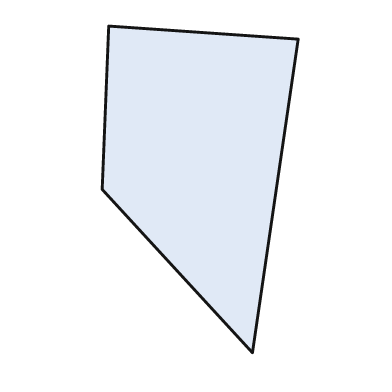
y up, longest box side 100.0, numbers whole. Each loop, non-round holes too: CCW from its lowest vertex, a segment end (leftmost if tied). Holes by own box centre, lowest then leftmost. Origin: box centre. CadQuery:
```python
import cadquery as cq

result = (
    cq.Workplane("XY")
    .moveTo(16.0, -50.0)
    .lineTo(30.0, 46.0)
    .lineTo(-28.0, 50.0)
    .lineTo(-30.0, 0.0)
    .close()
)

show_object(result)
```